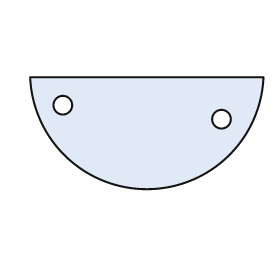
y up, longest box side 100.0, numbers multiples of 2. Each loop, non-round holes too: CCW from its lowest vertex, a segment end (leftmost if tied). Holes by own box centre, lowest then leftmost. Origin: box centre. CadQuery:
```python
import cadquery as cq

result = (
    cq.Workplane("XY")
    .moveTo(-50.0, 24.0)
    .threePointArc((0.0, -24.0), (50.0, 24.0))
    .close()
    .moveTo(32.0, 6.0)
    .circle(4.0)
    .moveTo(-36.0, 12.0)
    .circle(4.0)
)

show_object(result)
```